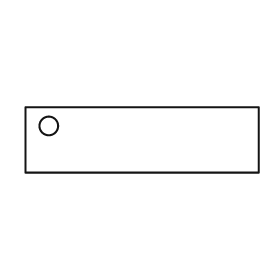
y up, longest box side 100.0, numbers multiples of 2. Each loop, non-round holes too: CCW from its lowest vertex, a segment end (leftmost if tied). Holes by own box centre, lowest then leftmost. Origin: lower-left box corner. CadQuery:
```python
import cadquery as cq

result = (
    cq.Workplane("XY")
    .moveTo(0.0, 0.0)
    .lineTo(100.0, 0.0)
    .lineTo(100.0, 28.0)
    .lineTo(0.0, 28.0)
    .close()
    .moveTo(10.0, 20.0)
    .circle(4.0)
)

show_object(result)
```